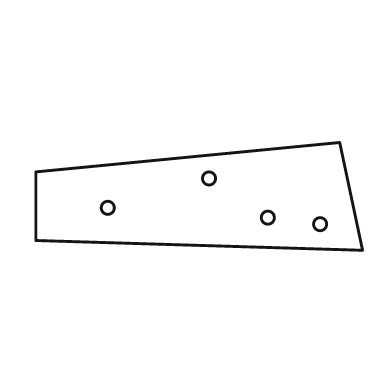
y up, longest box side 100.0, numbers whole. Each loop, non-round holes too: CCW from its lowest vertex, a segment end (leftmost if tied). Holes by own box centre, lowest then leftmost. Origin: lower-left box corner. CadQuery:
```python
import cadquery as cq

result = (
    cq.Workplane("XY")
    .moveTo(100.0, 0.0)
    .lineTo(93.0, 33.0)
    .lineTo(0.0, 24.0)
    .lineTo(0.0, 3.0)
    .close()
    .moveTo(87.0, 8.0)
    .circle(2.0)
    .moveTo(71.0, 10.0)
    .circle(2.0)
    .moveTo(22.0, 13.0)
    .circle(2.0)
    .moveTo(53.0, 22.0)
    .circle(2.0)
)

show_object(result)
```